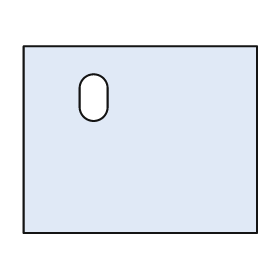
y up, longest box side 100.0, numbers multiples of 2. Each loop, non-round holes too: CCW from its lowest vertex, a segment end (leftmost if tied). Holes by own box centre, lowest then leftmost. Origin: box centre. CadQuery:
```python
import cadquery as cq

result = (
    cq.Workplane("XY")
    .moveTo(-50.0, -40.0)
    .lineTo(50.0, -40.0)
    .lineTo(50.0, 40.0)
    .lineTo(-50.0, 40.0)
    .close()
    .moveTo(-26.0, 14.0)
    .threePointArc((-20.0, 8.0), (-14.0, 14.0))
    .lineTo(-14.0, 22.0)
    .threePointArc((-20.0, 28.0), (-26.0, 22.0))
    .close()
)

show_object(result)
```